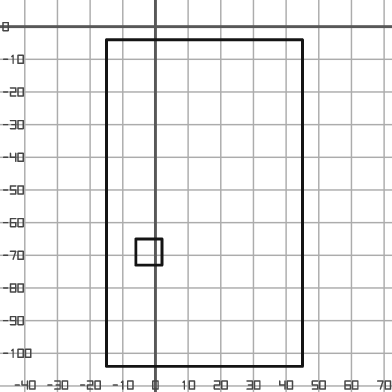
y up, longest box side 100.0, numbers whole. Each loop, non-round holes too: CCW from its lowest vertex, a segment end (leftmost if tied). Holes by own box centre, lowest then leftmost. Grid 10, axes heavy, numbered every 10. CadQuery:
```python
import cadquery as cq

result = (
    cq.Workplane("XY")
    .moveTo(-15.0, -104.0)
    .lineTo(45.0, -104.0)
    .lineTo(45.0, -4.0)
    .lineTo(-15.0, -4.0)
    .close()
    .moveTo(-6.0, -73.0)
    .lineTo(2.0, -73.0)
    .lineTo(2.0, -65.0)
    .lineTo(-6.0, -65.0)
    .close()
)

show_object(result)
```